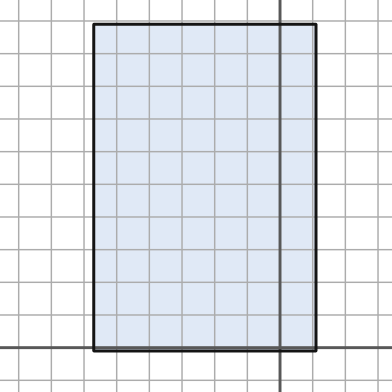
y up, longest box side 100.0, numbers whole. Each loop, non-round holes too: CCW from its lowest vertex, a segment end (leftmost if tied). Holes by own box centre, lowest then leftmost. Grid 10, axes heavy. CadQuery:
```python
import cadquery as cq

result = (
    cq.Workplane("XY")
    .moveTo(-57.0, -1.0)
    .lineTo(11.0, -1.0)
    .lineTo(11.0, 99.0)
    .lineTo(-57.0, 99.0)
    .close()
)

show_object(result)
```